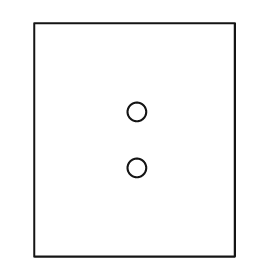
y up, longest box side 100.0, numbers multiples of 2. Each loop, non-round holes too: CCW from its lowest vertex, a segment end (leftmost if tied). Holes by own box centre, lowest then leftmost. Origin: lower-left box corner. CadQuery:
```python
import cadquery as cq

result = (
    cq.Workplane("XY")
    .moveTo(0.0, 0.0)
    .lineTo(86.0, 0.0)
    .lineTo(86.0, 100.0)
    .lineTo(0.0, 100.0)
    .close()
    .moveTo(44.0, 38.0)
    .circle(4.0)
    .moveTo(44.0, 62.0)
    .circle(4.0)
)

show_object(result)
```